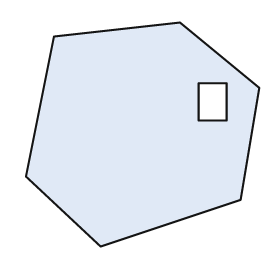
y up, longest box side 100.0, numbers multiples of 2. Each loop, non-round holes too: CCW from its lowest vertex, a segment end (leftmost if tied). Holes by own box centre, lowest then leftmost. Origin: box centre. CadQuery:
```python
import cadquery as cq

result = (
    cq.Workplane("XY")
    .moveTo(-18.0, -48.0)
    .lineTo(42.0, -28.0)
    .lineTo(50.0, 20.0)
    .lineTo(16.0, 48.0)
    .lineTo(-38.0, 42.0)
    .lineTo(-50.0, -18.0)
    .close()
    .moveTo(24.0, 6.0)
    .lineTo(36.0, 6.0)
    .lineTo(36.0, 22.0)
    .lineTo(24.0, 22.0)
    .close()
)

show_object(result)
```